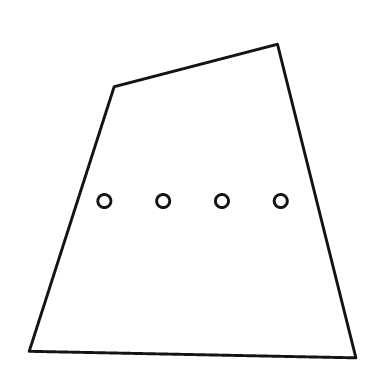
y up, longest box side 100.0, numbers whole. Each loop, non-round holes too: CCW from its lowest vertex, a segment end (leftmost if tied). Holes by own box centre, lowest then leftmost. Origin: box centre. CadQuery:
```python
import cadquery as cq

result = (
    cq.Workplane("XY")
    .moveTo(50.0, -48.0)
    .lineTo(26.0, 48.0)
    .lineTo(-24.0, 35.0)
    .lineTo(-50.0, -46.0)
    .close()
    .moveTo(-27.0, 0.0)
    .circle(2.0)
    .moveTo(-9.0, 0.0)
    .circle(2.0)
    .moveTo(9.0, 0.0)
    .circle(2.0)
    .moveTo(27.0, 0.0)
    .circle(2.0)
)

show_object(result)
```